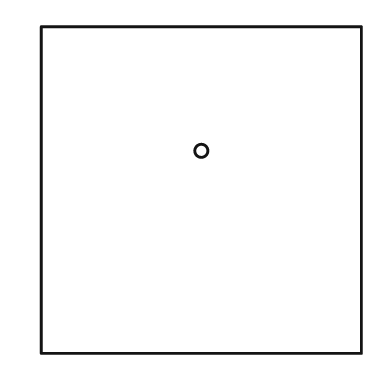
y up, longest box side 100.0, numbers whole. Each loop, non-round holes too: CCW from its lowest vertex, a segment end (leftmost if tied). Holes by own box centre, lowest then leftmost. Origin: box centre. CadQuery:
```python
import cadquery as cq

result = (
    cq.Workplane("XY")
    .moveTo(-49.0, -50.0)
    .lineTo(49.0, -50.0)
    .lineTo(49.0, 50.0)
    .lineTo(-49.0, 50.0)
    .close()
    .moveTo(0.0, 12.0)
    .circle(2.0)
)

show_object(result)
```